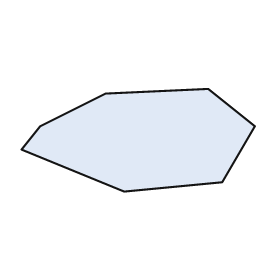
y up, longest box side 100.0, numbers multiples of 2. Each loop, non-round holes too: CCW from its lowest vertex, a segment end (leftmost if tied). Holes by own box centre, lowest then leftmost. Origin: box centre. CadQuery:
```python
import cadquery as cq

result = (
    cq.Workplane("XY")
    .moveTo(-6.0, -22.0)
    .lineTo(36.0, -18.0)
    .lineTo(50.0, 6.0)
    .lineTo(30.0, 22.0)
    .lineTo(-14.0, 20.0)
    .lineTo(-42.0, 6.0)
    .lineTo(-50.0, -4.0)
    .close()
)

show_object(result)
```